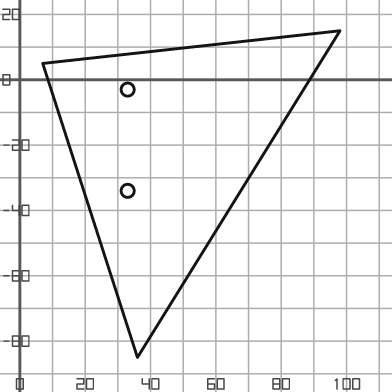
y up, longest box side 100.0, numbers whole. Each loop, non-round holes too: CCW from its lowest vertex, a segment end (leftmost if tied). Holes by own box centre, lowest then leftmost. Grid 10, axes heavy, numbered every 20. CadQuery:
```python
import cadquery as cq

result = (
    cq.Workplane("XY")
    .moveTo(36.0, -85.0)
    .lineTo(98.0, 15.0)
    .lineTo(7.0, 5.0)
    .close()
    .moveTo(33.0, -34.0)
    .circle(2.0)
    .moveTo(33.0, -3.0)
    .circle(2.0)
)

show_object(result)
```